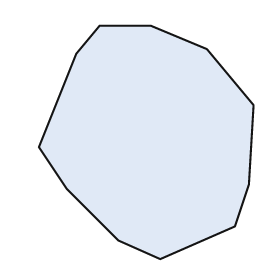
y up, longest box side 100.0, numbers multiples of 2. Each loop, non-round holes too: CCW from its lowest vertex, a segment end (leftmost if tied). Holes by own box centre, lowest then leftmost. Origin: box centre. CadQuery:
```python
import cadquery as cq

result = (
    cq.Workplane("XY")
    .moveTo(6.0, -50.0)
    .lineTo(38.0, -36.0)
    .lineTo(44.0, -18.0)
    .lineTo(46.0, 16.0)
    .lineTo(26.0, 40.0)
    .lineTo(2.0, 50.0)
    .lineTo(-20.0, 50.0)
    .lineTo(-30.0, 38.0)
    .lineTo(-46.0, -2.0)
    .lineTo(-34.0, -20.0)
    .lineTo(-12.0, -42.0)
    .close()
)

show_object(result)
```